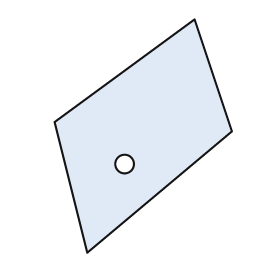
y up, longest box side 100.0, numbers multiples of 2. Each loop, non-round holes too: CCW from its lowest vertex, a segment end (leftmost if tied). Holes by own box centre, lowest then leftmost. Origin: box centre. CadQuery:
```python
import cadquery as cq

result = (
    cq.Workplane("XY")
    .moveTo(-24.0, -50.0)
    .lineTo(38.0, 2.0)
    .lineTo(22.0, 50.0)
    .lineTo(-38.0, 6.0)
    .close()
    .moveTo(-8.0, -12.0)
    .circle(4.0)
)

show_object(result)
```